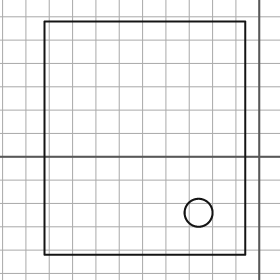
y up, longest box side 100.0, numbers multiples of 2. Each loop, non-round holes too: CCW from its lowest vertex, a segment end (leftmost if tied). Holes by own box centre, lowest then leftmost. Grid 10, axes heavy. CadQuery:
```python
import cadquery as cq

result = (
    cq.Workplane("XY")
    .moveTo(-92.0, -42.0)
    .lineTo(-6.0, -42.0)
    .lineTo(-6.0, 58.0)
    .lineTo(-92.0, 58.0)
    .close()
    .moveTo(-26.0, -24.0)
    .circle(6.0)
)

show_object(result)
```